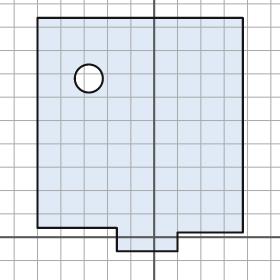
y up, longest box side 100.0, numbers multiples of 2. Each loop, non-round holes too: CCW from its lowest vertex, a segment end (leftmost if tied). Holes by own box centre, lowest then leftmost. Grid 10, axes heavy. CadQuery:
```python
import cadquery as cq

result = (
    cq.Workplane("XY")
    .moveTo(-16.0, -6.0)
    .lineTo(10.0, -6.0)
    .lineTo(10.0, 2.0)
    .lineTo(38.0, 2.0)
    .lineTo(38.0, 94.0)
    .lineTo(-50.0, 94.0)
    .lineTo(-50.0, 4.0)
    .lineTo(-16.0, 4.0)
    .close()
    .moveTo(-28.0, 68.0)
    .circle(6.0)
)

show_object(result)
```